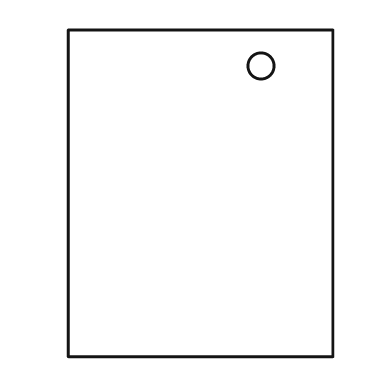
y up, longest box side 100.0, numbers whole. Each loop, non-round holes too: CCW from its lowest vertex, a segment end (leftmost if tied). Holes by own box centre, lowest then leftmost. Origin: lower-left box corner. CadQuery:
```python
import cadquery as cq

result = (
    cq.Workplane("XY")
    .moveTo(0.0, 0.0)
    .lineTo(81.0, 0.0)
    .lineTo(81.0, 100.0)
    .lineTo(0.0, 100.0)
    .close()
    .moveTo(59.0, 89.0)
    .circle(4.0)
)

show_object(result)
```